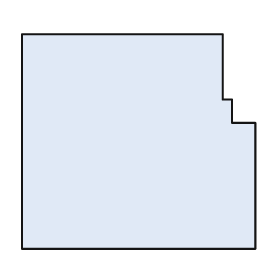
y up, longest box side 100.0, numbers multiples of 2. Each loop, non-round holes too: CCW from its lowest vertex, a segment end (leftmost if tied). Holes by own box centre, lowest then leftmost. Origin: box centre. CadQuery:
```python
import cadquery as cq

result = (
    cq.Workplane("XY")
    .moveTo(-50.0, -46.0)
    .lineTo(50.0, -46.0)
    .lineTo(50.0, 8.0)
    .lineTo(40.0, 8.0)
    .lineTo(40.0, 18.0)
    .lineTo(36.0, 18.0)
    .lineTo(36.0, 46.0)
    .lineTo(-50.0, 46.0)
    .close()
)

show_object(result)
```